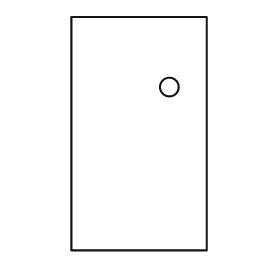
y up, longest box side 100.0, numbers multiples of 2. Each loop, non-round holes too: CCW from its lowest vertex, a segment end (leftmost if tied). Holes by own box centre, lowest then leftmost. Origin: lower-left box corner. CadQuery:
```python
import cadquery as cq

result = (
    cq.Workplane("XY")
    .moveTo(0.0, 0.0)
    .lineTo(58.0, 0.0)
    .lineTo(58.0, 100.0)
    .lineTo(0.0, 100.0)
    .close()
    .moveTo(42.0, 70.0)
    .circle(4.0)
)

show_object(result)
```